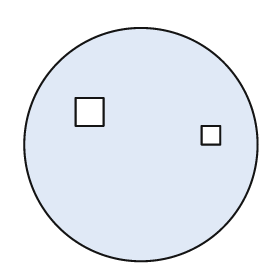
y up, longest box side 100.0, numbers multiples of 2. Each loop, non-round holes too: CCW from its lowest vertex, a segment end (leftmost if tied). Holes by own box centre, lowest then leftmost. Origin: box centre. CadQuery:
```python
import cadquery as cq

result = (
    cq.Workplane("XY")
    .moveTo(0.0, 0.0)
    .circle(50.0)
    .moveTo(26.0, 0.0)
    .lineTo(34.0, 0.0)
    .lineTo(34.0, 8.0)
    .lineTo(26.0, 8.0)
    .close()
    .moveTo(-28.0, 8.0)
    .lineTo(-16.0, 8.0)
    .lineTo(-16.0, 20.0)
    .lineTo(-28.0, 20.0)
    .close()
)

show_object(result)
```